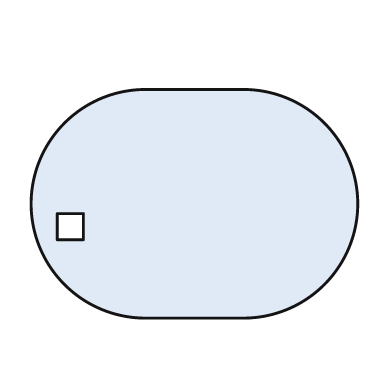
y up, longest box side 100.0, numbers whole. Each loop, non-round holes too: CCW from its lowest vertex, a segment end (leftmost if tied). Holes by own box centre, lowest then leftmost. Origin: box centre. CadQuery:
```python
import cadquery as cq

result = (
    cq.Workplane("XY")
    .moveTo(-15.0, -35.0)
    .lineTo(15.0, -35.0)
    .threePointArc((50.0, 0.0), (15.0, 35.0))
    .lineTo(-15.0, 35.0)
    .threePointArc((-50.0, 0.0), (-15.0, -35.0))
    .close()
    .moveTo(-42.0, -11.0)
    .lineTo(-34.0, -11.0)
    .lineTo(-34.0, -3.0)
    .lineTo(-42.0, -3.0)
    .close()
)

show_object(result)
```